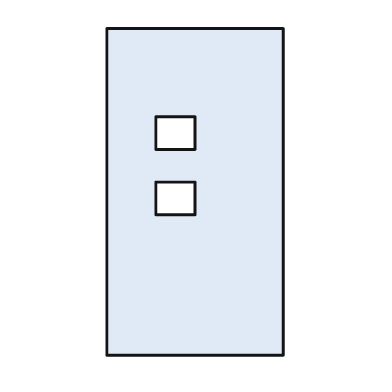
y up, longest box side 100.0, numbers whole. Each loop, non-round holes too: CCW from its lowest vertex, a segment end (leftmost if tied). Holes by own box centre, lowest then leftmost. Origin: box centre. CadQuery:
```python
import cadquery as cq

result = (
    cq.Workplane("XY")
    .moveTo(-27.0, -50.0)
    .lineTo(27.0, -50.0)
    .lineTo(27.0, 50.0)
    .lineTo(-27.0, 50.0)
    .close()
    .moveTo(-12.0, -7.0)
    .lineTo(0.0, -7.0)
    .lineTo(0.0, 3.0)
    .lineTo(-12.0, 3.0)
    .close()
    .moveTo(-12.0, 13.0)
    .lineTo(0.0, 13.0)
    .lineTo(0.0, 23.0)
    .lineTo(-12.0, 23.0)
    .close()
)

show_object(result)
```